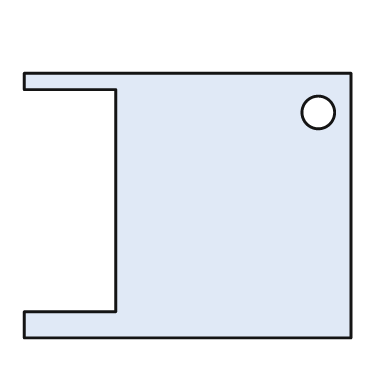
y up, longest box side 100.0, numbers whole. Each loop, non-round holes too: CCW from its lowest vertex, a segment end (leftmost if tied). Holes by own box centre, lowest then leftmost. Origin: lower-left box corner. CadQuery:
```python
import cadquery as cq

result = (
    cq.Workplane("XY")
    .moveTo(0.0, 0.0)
    .lineTo(100.0, 0.0)
    .lineTo(100.0, 81.0)
    .lineTo(0.0, 81.0)
    .lineTo(0.0, 76.0)
    .lineTo(28.0, 76.0)
    .lineTo(28.0, 8.0)
    .lineTo(0.0, 8.0)
    .close()
    .moveTo(90.0, 69.0)
    .circle(5.0)
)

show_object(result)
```